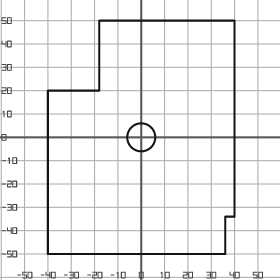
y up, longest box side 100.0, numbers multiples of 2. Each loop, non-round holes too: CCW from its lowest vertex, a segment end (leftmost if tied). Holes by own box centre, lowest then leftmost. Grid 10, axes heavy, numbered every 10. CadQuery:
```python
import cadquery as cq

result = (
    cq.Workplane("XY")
    .moveTo(-40.0, -50.0)
    .lineTo(36.0, -50.0)
    .lineTo(36.0, -34.0)
    .lineTo(40.0, -34.0)
    .lineTo(40.0, 50.0)
    .lineTo(-18.0, 50.0)
    .lineTo(-18.0, 20.0)
    .lineTo(-40.0, 20.0)
    .close()
    .moveTo(0.0, 0.0)
    .circle(6.0)
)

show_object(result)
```